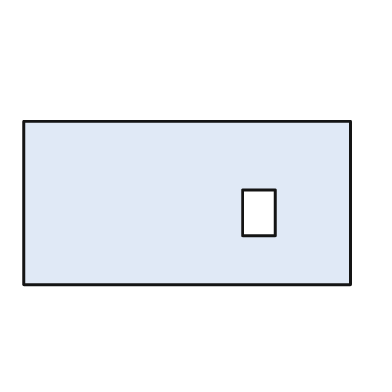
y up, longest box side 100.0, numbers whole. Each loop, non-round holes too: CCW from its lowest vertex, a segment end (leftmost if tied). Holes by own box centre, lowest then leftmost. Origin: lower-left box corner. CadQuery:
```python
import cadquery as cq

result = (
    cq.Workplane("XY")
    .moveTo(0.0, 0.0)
    .lineTo(100.0, 0.0)
    .lineTo(100.0, 50.0)
    .lineTo(0.0, 50.0)
    .close()
    .moveTo(67.0, 15.0)
    .lineTo(77.0, 15.0)
    .lineTo(77.0, 29.0)
    .lineTo(67.0, 29.0)
    .close()
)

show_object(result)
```